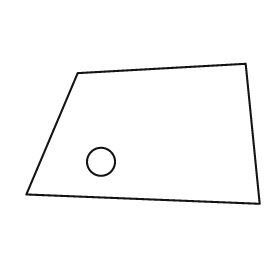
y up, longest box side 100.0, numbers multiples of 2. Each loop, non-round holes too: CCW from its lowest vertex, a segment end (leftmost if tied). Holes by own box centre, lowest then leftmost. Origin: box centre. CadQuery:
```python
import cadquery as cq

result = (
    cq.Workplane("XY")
    .moveTo(50.0, -30.0)
    .lineTo(44.0, 30.0)
    .lineTo(-28.0, 26.0)
    .lineTo(-50.0, -26.0)
    .close()
    .moveTo(-18.0, -12.0)
    .circle(6.0)
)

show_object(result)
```